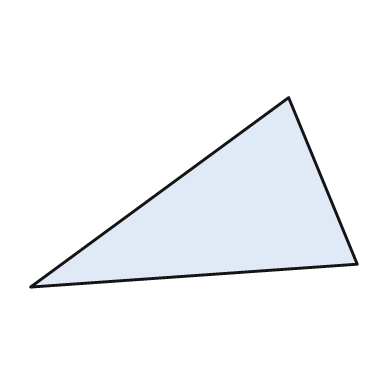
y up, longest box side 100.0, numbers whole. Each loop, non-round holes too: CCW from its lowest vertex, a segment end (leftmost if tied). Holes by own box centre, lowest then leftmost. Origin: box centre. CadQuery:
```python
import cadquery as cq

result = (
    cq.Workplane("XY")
    .moveTo(-50.0, -29.0)
    .lineTo(50.0, -22.0)
    .lineTo(29.0, 29.0)
    .close()
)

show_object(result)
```